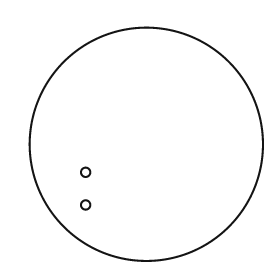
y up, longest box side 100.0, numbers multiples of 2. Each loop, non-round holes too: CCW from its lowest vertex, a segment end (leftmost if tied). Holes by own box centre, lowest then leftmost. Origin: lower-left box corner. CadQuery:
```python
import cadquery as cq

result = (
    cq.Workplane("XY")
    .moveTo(50.0, 50.0)
    .circle(50.0)
    .moveTo(24.0, 24.0)
    .circle(2.0)
    .moveTo(24.0, 38.0)
    .circle(2.0)
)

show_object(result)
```